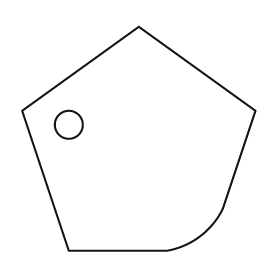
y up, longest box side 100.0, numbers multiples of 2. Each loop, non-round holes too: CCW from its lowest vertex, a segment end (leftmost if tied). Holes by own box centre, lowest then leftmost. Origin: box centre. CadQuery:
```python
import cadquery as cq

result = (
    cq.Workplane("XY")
    .moveTo(-30.0, -48.0)
    .lineTo(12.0, -48.0)
    .threePointArc((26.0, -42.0), (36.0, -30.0))
    .lineTo(50.0, 12.0)
    .lineTo(0.0, 48.0)
    .lineTo(-50.0, 12.0)
    .close()
    .moveTo(-30.0, 6.0)
    .circle(6.0)
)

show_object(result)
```